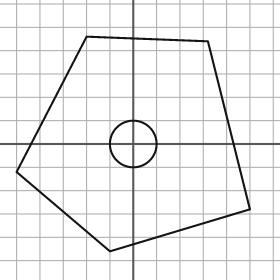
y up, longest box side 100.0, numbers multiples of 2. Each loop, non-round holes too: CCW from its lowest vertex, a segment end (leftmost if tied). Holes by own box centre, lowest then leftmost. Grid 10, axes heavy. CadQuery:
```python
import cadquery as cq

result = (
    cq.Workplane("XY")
    .moveTo(-10.0, -46.0)
    .lineTo(50.0, -28.0)
    .lineTo(32.0, 44.0)
    .lineTo(-20.0, 46.0)
    .lineTo(-50.0, -12.0)
    .close()
    .moveTo(0.0, 0.0)
    .circle(10.0)
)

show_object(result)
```